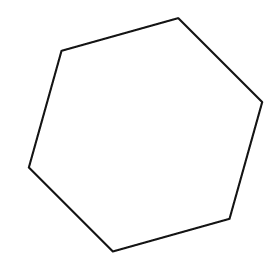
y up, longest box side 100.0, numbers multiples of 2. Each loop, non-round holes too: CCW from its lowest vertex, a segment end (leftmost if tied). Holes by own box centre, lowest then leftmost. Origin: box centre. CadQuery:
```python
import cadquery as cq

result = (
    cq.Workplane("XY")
    .moveTo(-14.0, -50.0)
    .lineTo(36.0, -36.0)
    .lineTo(50.0, 14.0)
    .lineTo(14.0, 50.0)
    .lineTo(-36.0, 36.0)
    .lineTo(-50.0, -14.0)
    .close()
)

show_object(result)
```